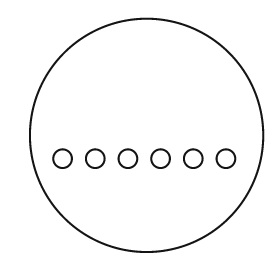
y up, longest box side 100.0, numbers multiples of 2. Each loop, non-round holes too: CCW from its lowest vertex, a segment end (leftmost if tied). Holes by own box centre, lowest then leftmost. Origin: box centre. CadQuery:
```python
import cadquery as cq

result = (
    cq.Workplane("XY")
    .moveTo(0.0, 0.0)
    .circle(50.0)
    .moveTo(-36.0, -10.0)
    .circle(4.0)
    .moveTo(-22.0, -10.0)
    .circle(4.0)
    .moveTo(-8.0, -10.0)
    .circle(4.0)
    .moveTo(6.0, -10.0)
    .circle(4.0)
    .moveTo(20.0, -10.0)
    .circle(4.0)
    .moveTo(34.0, -10.0)
    .circle(4.0)
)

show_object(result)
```